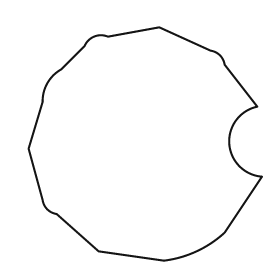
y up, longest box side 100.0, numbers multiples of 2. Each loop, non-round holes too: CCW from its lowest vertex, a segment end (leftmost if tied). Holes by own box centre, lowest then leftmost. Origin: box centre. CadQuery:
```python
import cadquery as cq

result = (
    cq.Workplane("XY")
    .moveTo(8.0, -50.0)
    .threePointArc((22.0, -46.0), (34.0, -38.0))
    .lineTo(50.0, -14.0)
    .threePointArc((36.0, 0.0), (48.0, 16.0))
    .lineTo(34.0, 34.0)
    .threePointArc((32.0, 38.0), (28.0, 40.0))
    .lineTo(6.0, 50.0)
    .lineTo(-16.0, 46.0)
    .threePointArc((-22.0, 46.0), (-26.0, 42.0))
    .lineTo(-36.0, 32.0)
    .threePointArc((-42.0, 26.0), (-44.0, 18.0))
    .lineTo(-50.0, -2.0)
    .lineTo(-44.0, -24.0)
    .threePointArc((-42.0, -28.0), (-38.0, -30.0))
    .lineTo(-20.0, -46.0)
    .close()
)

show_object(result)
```